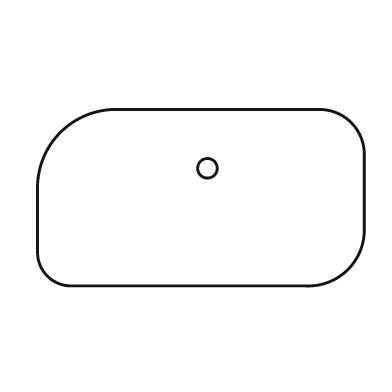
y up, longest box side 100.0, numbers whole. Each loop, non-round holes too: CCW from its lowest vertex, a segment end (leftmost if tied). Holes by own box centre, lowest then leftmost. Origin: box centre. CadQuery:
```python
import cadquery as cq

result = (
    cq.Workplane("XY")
    .moveTo(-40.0, -27.0)
    .lineTo(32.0, -27.0)
    .threePointArc((45.0, -22.0), (50.0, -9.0))
    .lineTo(50.0, 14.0)
    .threePointArc((46.0, 23.0), (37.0, 27.0))
    .lineTo(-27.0, 27.0)
    .threePointArc((-43.0, 20.0), (-50.0, 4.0))
    .lineTo(-50.0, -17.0)
    .threePointArc((-47.0, -24.0), (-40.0, -27.0))
    .close()
    .moveTo(2.0, 9.0)
    .circle(3.0)
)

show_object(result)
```